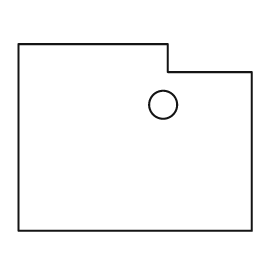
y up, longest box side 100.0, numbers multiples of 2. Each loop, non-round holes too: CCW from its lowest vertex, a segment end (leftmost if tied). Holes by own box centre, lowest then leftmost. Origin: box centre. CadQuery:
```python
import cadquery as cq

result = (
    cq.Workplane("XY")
    .moveTo(-50.0, -40.0)
    .lineTo(50.0, -40.0)
    .lineTo(50.0, 28.0)
    .lineTo(14.0, 28.0)
    .lineTo(14.0, 40.0)
    .lineTo(-50.0, 40.0)
    .close()
    .moveTo(12.0, 14.0)
    .circle(6.0)
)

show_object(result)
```